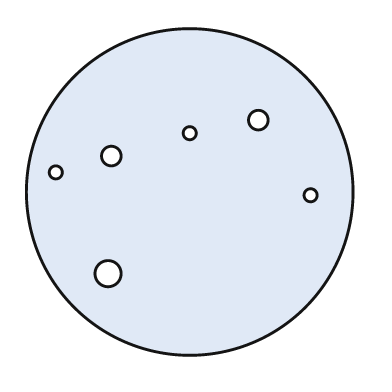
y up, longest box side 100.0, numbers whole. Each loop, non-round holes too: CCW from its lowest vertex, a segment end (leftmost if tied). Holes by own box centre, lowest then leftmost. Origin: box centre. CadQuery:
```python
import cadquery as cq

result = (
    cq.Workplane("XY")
    .moveTo(0.0, 0.0)
    .circle(50.0)
    .moveTo(-25.0, -25.0)
    .circle(4.0)
    .moveTo(37.0, -1.0)
    .circle(2.0)
    .moveTo(-41.0, 6.0)
    .circle(2.0)
    .moveTo(-24.0, 11.0)
    .circle(3.0)
    .moveTo(0.0, 18.0)
    .circle(2.0)
    .moveTo(21.0, 22.0)
    .circle(3.0)
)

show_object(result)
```